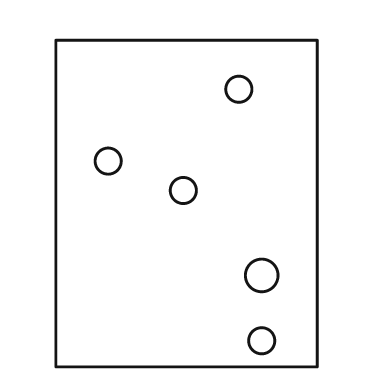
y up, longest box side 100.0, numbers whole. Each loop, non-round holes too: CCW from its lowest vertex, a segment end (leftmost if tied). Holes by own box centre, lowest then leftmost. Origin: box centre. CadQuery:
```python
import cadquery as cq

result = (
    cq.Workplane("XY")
    .moveTo(-40.0, -50.0)
    .lineTo(40.0, -50.0)
    .lineTo(40.0, 50.0)
    .lineTo(-40.0, 50.0)
    .close()
    .moveTo(23.0, -42.0)
    .circle(4.0)
    .moveTo(23.0, -22.0)
    .circle(5.0)
    .moveTo(-1.0, 4.0)
    .circle(4.0)
    .moveTo(-24.0, 13.0)
    .circle(4.0)
    .moveTo(16.0, 35.0)
    .circle(4.0)
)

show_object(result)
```